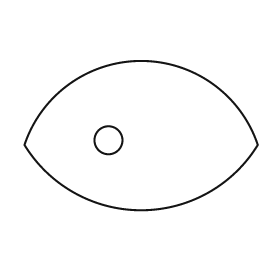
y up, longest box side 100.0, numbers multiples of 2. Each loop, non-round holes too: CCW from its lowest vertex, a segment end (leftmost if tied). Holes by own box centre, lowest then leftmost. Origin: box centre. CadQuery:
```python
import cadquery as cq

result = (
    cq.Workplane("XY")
    .moveTo(-50.0, -4.0)
    .threePointArc((0.0, -32.0), (50.0, -4.0))
    .threePointArc((0.0, 32.0), (-50.0, -4.0))
    .close()
    .moveTo(-14.0, -2.0)
    .circle(6.0)
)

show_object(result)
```